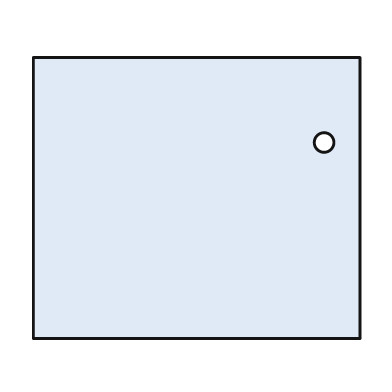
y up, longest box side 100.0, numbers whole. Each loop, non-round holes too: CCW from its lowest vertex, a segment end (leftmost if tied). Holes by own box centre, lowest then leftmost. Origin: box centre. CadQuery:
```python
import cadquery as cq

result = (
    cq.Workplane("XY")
    .moveTo(-50.0, -43.0)
    .lineTo(50.0, -43.0)
    .lineTo(50.0, 43.0)
    .lineTo(-50.0, 43.0)
    .close()
    .moveTo(39.0, 17.0)
    .circle(3.0)
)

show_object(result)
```